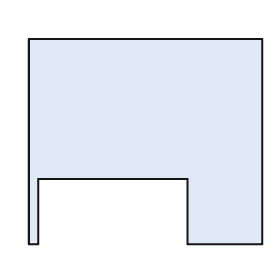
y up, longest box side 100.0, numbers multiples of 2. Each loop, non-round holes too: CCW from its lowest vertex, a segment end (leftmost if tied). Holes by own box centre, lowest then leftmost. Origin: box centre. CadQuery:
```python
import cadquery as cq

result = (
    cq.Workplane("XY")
    .moveTo(-50.0, -44.0)
    .lineTo(-46.0, -44.0)
    .lineTo(-46.0, -16.0)
    .lineTo(18.0, -16.0)
    .lineTo(18.0, -44.0)
    .lineTo(50.0, -44.0)
    .lineTo(50.0, 44.0)
    .lineTo(-50.0, 44.0)
    .close()
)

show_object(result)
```